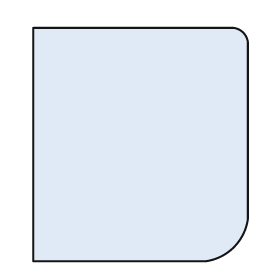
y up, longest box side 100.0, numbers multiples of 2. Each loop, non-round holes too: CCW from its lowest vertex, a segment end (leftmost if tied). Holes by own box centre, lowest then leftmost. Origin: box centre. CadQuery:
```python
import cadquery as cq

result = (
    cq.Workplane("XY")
    .moveTo(-46.0, -50.0)
    .lineTo(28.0, -50.0)
    .threePointArc((40.0, -44.0), (46.0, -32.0))
    .lineTo(46.0, 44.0)
    .threePointArc((44.0, 48.0), (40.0, 50.0))
    .lineTo(-46.0, 50.0)
    .close()
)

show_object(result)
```